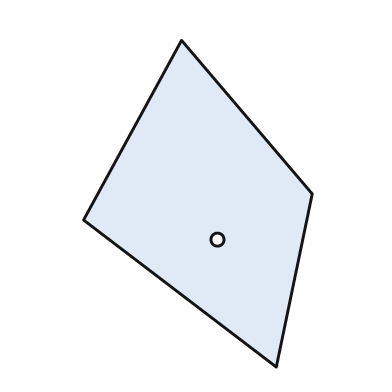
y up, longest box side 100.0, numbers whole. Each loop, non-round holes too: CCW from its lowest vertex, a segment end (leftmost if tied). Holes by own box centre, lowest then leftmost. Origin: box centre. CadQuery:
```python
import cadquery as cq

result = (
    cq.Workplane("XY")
    .moveTo(24.0, -50.0)
    .lineTo(35.0, 3.0)
    .lineTo(-5.0, 50.0)
    .lineTo(-35.0, -5.0)
    .close()
    .moveTo(6.0, -11.0)
    .circle(2.0)
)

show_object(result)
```